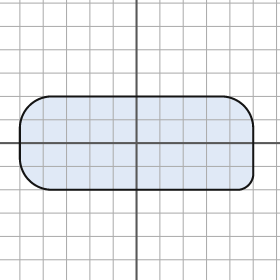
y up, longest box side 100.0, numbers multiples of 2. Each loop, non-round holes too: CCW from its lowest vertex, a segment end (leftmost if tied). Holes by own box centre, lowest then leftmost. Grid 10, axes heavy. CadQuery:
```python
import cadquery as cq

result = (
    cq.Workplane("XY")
    .moveTo(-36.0, -20.0)
    .lineTo(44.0, -20.0)
    .threePointArc((48.0, -18.0), (50.0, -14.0))
    .lineTo(50.0, 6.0)
    .threePointArc((46.0, 16.0), (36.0, 20.0))
    .lineTo(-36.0, 20.0)
    .threePointArc((-46.0, 16.0), (-50.0, 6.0))
    .lineTo(-50.0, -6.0)
    .threePointArc((-46.0, -16.0), (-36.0, -20.0))
    .close()
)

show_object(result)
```